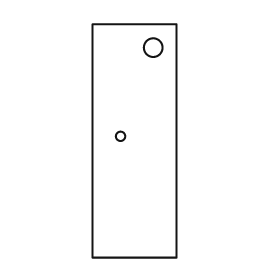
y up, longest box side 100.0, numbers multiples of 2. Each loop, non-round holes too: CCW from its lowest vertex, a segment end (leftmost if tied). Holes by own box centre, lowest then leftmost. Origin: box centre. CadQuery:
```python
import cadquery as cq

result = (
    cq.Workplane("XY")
    .moveTo(-18.0, -50.0)
    .lineTo(18.0, -50.0)
    .lineTo(18.0, 50.0)
    .lineTo(-18.0, 50.0)
    .close()
    .moveTo(-6.0, 2.0)
    .circle(2.0)
    .moveTo(8.0, 40.0)
    .circle(4.0)
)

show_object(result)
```